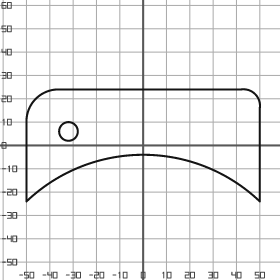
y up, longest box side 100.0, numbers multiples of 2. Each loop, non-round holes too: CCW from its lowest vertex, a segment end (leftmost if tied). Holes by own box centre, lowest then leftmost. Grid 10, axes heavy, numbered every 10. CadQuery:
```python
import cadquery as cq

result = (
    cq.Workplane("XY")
    .moveTo(-50.0, -24.0)
    .threePointArc((0.0, -4.0), (50.0, -24.0))
    .lineTo(50.0, 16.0)
    .threePointArc((48.0, 22.0), (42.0, 24.0))
    .lineTo(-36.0, 24.0)
    .threePointArc((-46.0, 20.0), (-50.0, 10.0))
    .close()
    .moveTo(-32.0, 6.0)
    .circle(4.0)
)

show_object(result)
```